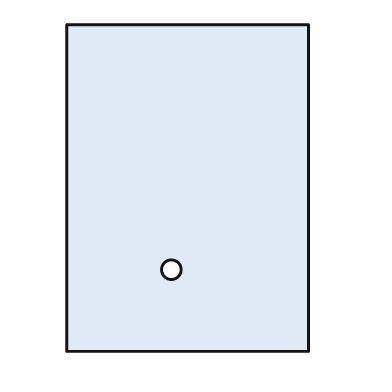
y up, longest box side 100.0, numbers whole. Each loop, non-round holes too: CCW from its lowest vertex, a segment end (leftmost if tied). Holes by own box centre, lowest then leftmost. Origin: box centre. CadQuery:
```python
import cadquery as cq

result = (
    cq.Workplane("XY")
    .moveTo(-37.0, -50.0)
    .lineTo(37.0, -50.0)
    .lineTo(37.0, 50.0)
    .lineTo(-37.0, 50.0)
    .close()
    .moveTo(-5.0, -25.0)
    .circle(3.0)
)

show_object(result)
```